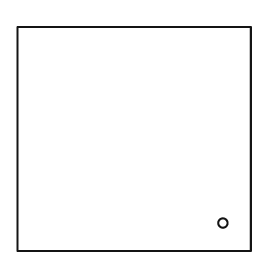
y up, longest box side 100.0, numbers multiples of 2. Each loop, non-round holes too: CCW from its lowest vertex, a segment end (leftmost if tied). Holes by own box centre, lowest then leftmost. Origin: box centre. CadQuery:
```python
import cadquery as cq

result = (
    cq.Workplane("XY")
    .moveTo(-50.0, -48.0)
    .lineTo(50.0, -48.0)
    .lineTo(50.0, 48.0)
    .lineTo(-50.0, 48.0)
    .close()
    .moveTo(38.0, -36.0)
    .circle(2.0)
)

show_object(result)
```